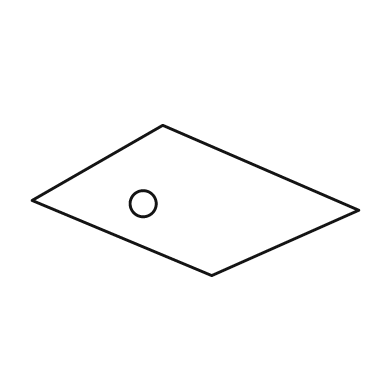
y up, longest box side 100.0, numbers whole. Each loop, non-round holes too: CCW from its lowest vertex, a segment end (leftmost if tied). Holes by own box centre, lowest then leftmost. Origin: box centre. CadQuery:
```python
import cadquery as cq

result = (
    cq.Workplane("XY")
    .moveTo(5.0, -23.0)
    .lineTo(50.0, -3.0)
    .lineTo(-10.0, 23.0)
    .lineTo(-50.0, 0.0)
    .close()
    .moveTo(-16.0, -1.0)
    .circle(4.0)
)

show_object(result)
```